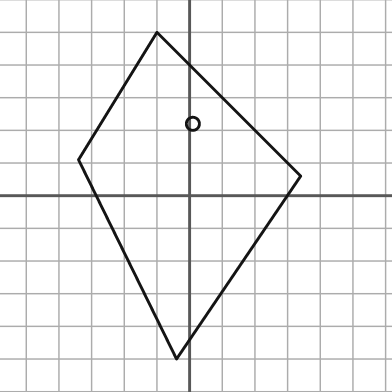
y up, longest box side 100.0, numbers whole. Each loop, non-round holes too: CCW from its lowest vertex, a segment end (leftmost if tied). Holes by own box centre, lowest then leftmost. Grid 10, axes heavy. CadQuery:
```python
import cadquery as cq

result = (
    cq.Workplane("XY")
    .moveTo(-4.0, -50.0)
    .lineTo(34.0, 6.0)
    .lineTo(-10.0, 50.0)
    .lineTo(-34.0, 11.0)
    .close()
    .moveTo(1.0, 22.0)
    .circle(2.0)
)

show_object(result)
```